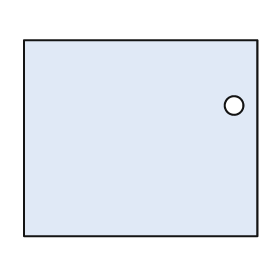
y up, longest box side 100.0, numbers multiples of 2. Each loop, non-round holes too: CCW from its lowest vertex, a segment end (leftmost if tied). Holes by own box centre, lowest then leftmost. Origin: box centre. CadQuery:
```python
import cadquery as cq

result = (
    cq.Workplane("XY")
    .moveTo(-50.0, -42.0)
    .lineTo(50.0, -42.0)
    .lineTo(50.0, 42.0)
    .lineTo(-50.0, 42.0)
    .close()
    .moveTo(40.0, 14.0)
    .circle(4.0)
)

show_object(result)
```